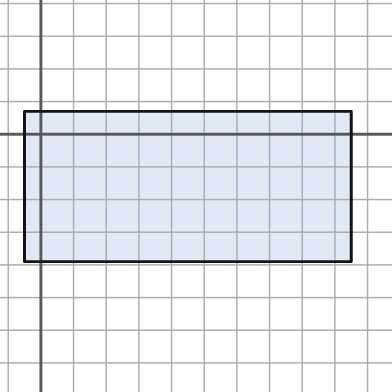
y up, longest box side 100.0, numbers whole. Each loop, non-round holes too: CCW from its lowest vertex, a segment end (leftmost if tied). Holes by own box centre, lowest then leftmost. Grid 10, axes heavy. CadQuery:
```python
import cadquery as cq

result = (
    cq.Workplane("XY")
    .moveTo(-5.0, -39.0)
    .lineTo(95.0, -39.0)
    .lineTo(95.0, 7.0)
    .lineTo(-5.0, 7.0)
    .close()
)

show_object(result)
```